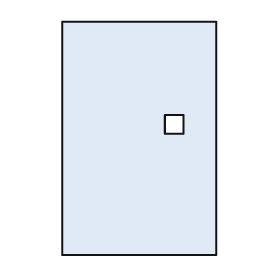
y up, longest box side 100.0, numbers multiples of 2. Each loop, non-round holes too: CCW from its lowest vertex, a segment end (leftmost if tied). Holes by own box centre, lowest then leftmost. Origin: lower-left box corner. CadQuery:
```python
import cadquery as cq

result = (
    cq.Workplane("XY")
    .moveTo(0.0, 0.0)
    .lineTo(66.0, 0.0)
    .lineTo(66.0, 100.0)
    .lineTo(0.0, 100.0)
    .close()
    .moveTo(44.0, 52.0)
    .lineTo(52.0, 52.0)
    .lineTo(52.0, 60.0)
    .lineTo(44.0, 60.0)
    .close()
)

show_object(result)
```